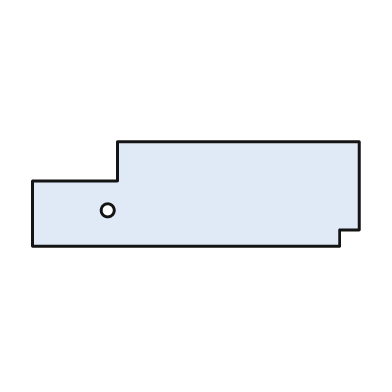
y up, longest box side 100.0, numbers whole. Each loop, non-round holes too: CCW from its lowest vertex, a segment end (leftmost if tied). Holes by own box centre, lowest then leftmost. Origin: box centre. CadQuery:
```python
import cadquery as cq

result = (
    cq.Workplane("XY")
    .moveTo(-50.0, -16.0)
    .lineTo(44.0, -16.0)
    .lineTo(44.0, -11.0)
    .lineTo(50.0, -11.0)
    .lineTo(50.0, 16.0)
    .lineTo(-24.0, 16.0)
    .lineTo(-24.0, 4.0)
    .lineTo(-50.0, 4.0)
    .close()
    .moveTo(-27.0, -5.0)
    .circle(2.0)
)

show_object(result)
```